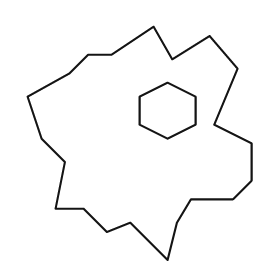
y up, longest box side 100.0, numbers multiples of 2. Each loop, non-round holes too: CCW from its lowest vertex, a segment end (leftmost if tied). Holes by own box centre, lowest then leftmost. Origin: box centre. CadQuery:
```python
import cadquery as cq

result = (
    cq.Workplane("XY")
    .moveTo(12.0, -50.0)
    .lineTo(16.0, -34.0)
    .lineTo(22.0, -24.0)
    .lineTo(40.0, -24.0)
    .lineTo(48.0, -16.0)
    .lineTo(48.0, 0.0)
    .lineTo(32.0, 8.0)
    .lineTo(42.0, 32.0)
    .lineTo(30.0, 46.0)
    .lineTo(14.0, 36.0)
    .lineTo(6.0, 50.0)
    .lineTo(-12.0, 38.0)
    .lineTo(-22.0, 38.0)
    .lineTo(-30.0, 30.0)
    .lineTo(-48.0, 20.0)
    .lineTo(-42.0, 2.0)
    .lineTo(-32.0, -8.0)
    .lineTo(-36.0, -28.0)
    .lineTo(-24.0, -28.0)
    .lineTo(-14.0, -38.0)
    .lineTo(-4.0, -34.0)
    .close()
    .moveTo(12.0, 2.0)
    .lineTo(24.0, 8.0)
    .lineTo(24.0, 20.0)
    .lineTo(12.0, 26.0)
    .lineTo(0.0, 20.0)
    .lineTo(0.0, 8.0)
    .close()
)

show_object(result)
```